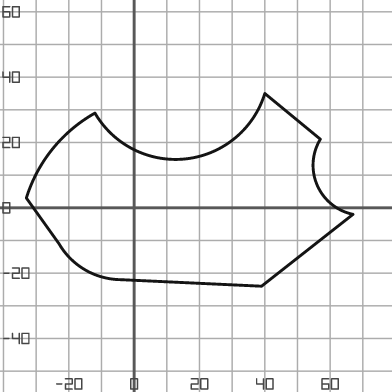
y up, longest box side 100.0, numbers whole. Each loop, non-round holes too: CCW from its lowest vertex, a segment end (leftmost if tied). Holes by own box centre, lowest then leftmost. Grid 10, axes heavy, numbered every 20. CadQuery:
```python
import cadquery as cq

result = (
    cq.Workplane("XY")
    .moveTo(39.0, -24.0)
    .lineTo(67.0, -2.0)
    .threePointArc((56.0, 7.0), (57.0, 21.0))
    .lineTo(40.0, 35.0)
    .threePointArc((16.0, 15.0), (-12.0, 29.0))
    .threePointArc((-25.0, 18.0), (-33.0, 3.0))
    .lineTo(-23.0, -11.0)
    .threePointArc((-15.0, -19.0), (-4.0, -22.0))
    .close()
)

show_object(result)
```